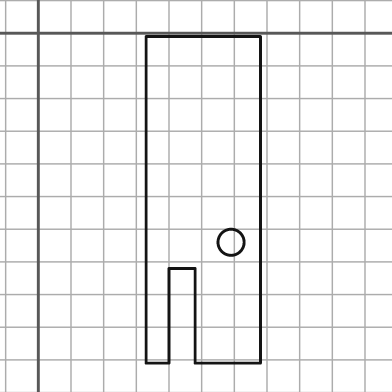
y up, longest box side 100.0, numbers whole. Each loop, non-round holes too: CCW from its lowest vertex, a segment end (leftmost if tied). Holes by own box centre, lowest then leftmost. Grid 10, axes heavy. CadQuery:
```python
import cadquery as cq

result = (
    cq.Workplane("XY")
    .moveTo(33.0, -101.0)
    .lineTo(40.0, -101.0)
    .lineTo(40.0, -72.0)
    .lineTo(48.0, -72.0)
    .lineTo(48.0, -101.0)
    .lineTo(68.0, -101.0)
    .lineTo(68.0, -1.0)
    .lineTo(33.0, -1.0)
    .close()
    .moveTo(59.0, -64.0)
    .circle(4.0)
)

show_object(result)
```